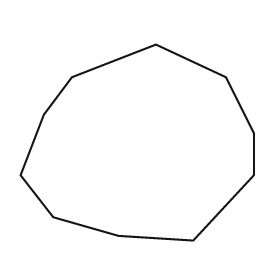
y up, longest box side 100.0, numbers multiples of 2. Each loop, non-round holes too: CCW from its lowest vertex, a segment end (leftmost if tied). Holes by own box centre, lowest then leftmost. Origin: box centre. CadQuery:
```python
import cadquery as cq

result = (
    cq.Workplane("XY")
    .moveTo(24.0, -42.0)
    .lineTo(50.0, -14.0)
    .lineTo(50.0, 4.0)
    .lineTo(38.0, 28.0)
    .lineTo(8.0, 42.0)
    .lineTo(-28.0, 28.0)
    .lineTo(-40.0, 12.0)
    .lineTo(-50.0, -14.0)
    .lineTo(-36.0, -32.0)
    .lineTo(-8.0, -40.0)
    .close()
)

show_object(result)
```